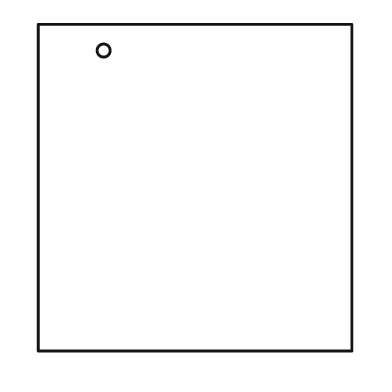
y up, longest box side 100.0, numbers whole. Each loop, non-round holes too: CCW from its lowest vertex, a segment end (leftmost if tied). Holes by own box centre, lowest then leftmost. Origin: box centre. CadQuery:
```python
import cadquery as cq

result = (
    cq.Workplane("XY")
    .moveTo(-48.0, -50.0)
    .lineTo(48.0, -50.0)
    .lineTo(48.0, 50.0)
    .lineTo(-48.0, 50.0)
    .close()
    .moveTo(-28.0, 42.0)
    .circle(2.0)
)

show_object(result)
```